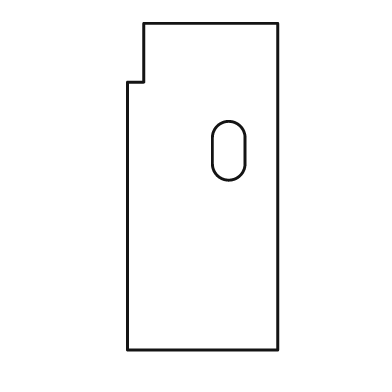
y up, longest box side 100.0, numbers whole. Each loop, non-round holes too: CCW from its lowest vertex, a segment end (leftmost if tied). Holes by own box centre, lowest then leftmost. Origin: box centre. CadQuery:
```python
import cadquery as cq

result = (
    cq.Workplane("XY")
    .moveTo(-23.0, -50.0)
    .lineTo(23.0, -50.0)
    .lineTo(23.0, 50.0)
    .lineTo(-18.0, 50.0)
    .lineTo(-18.0, 32.0)
    .lineTo(-23.0, 32.0)
    .close()
    .moveTo(3.0, 7.0)
    .threePointArc((8.0, 2.0), (13.0, 7.0))
    .lineTo(13.0, 15.0)
    .threePointArc((8.0, 20.0), (3.0, 15.0))
    .close()
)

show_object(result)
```